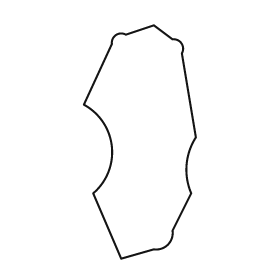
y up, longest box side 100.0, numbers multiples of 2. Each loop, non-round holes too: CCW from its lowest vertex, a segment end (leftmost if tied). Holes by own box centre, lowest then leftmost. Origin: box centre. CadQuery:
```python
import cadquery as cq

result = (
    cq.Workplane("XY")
    .moveTo(-8.0, -50.0)
    .lineTo(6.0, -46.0)
    .threePointArc((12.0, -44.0), (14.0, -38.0))
    .lineTo(22.0, -22.0)
    .threePointArc((20.0, -10.0), (24.0, 2.0))
    .lineTo(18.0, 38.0)
    .threePointArc((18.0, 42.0), (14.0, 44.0))
    .lineTo(6.0, 50.0)
    .lineTo(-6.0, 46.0)
    .threePointArc((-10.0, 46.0), (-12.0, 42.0))
    .lineTo(-24.0, 16.0)
    .threePointArc((-12.0, -2.0), (-20.0, -22.0))
    .close()
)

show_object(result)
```